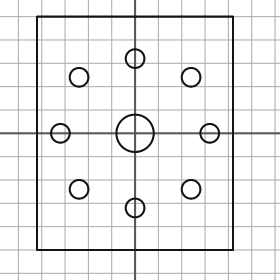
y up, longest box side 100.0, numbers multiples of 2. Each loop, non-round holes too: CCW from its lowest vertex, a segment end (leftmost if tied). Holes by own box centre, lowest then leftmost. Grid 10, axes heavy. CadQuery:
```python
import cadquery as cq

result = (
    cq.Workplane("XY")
    .moveTo(-42.0, -50.0)
    .lineTo(42.0, -50.0)
    .lineTo(42.0, 50.0)
    .lineTo(-42.0, 50.0)
    .close()
    .moveTo(0.0, -32.0)
    .circle(4.0)
    .moveTo(-24.0, -24.0)
    .circle(4.0)
    .moveTo(24.0, -24.0)
    .circle(4.0)
    .moveTo(-32.0, 0.0)
    .circle(4.0)
    .moveTo(0.0, 0.0)
    .circle(8.0)
    .moveTo(32.0, 0.0)
    .circle(4.0)
    .moveTo(-24.0, 24.0)
    .circle(4.0)
    .moveTo(24.0, 24.0)
    .circle(4.0)
    .moveTo(0.0, 32.0)
    .circle(4.0)
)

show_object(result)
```